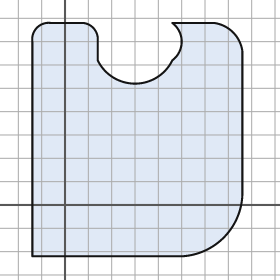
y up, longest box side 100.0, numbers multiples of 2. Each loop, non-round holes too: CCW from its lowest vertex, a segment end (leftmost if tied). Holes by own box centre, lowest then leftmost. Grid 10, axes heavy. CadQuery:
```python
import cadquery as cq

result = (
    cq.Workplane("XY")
    .moveTo(-14.0, -22.0)
    .lineTo(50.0, -22.0)
    .threePointArc((68.0, -14.0), (76.0, 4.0))
    .lineTo(76.0, 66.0)
    .threePointArc((72.0, 74.0), (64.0, 78.0))
    .lineTo(46.0, 78.0)
    .threePointArc((50.0, 70.0), (46.0, 62.0))
    .threePointArc((30.0, 52.0), (14.0, 62.0))
    .lineTo(14.0, 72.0)
    .threePointArc((12.0, 76.0), (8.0, 78.0))
    .lineTo(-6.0, 78.0)
    .threePointArc((-12.0, 76.0), (-14.0, 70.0))
    .close()
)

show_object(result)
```